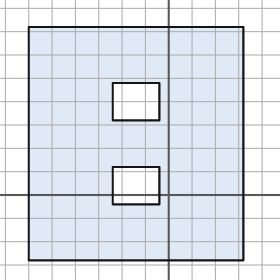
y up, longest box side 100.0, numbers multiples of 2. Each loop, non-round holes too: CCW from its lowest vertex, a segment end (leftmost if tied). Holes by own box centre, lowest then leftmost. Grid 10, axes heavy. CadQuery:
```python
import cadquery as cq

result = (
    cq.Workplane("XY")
    .moveTo(-60.0, -28.0)
    .lineTo(32.0, -28.0)
    .lineTo(32.0, 72.0)
    .lineTo(-60.0, 72.0)
    .close()
    .moveTo(-24.0, -4.0)
    .lineTo(-4.0, -4.0)
    .lineTo(-4.0, 12.0)
    .lineTo(-24.0, 12.0)
    .close()
    .moveTo(-24.0, 32.0)
    .lineTo(-4.0, 32.0)
    .lineTo(-4.0, 48.0)
    .lineTo(-24.0, 48.0)
    .close()
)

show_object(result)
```